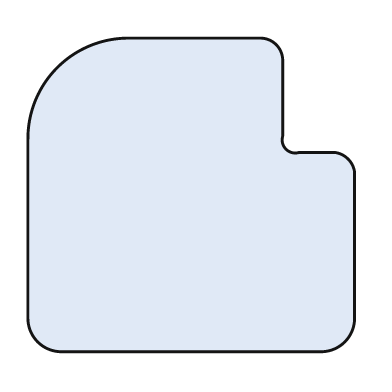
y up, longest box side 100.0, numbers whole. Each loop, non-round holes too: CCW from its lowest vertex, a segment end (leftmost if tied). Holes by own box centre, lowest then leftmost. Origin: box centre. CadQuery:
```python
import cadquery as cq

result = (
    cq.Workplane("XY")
    .moveTo(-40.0, -48.0)
    .lineTo(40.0, -48.0)
    .threePointArc((47.0, -45.0), (50.0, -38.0))
    .lineTo(50.0, 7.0)
    .threePointArc((48.0, 11.0), (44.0, 13.0))
    .lineTo(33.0, 13.0)
    .threePointArc((29.0, 14.0), (28.0, 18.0))
    .lineTo(28.0, 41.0)
    .threePointArc((26.0, 46.0), (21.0, 48.0))
    .lineTo(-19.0, 48.0)
    .threePointArc((-41.0, 39.0), (-50.0, 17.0))
    .lineTo(-50.0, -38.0)
    .threePointArc((-47.0, -45.0), (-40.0, -48.0))
    .close()
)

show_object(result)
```